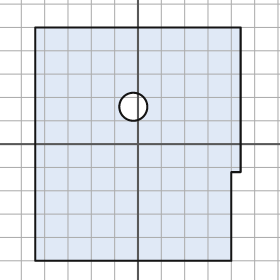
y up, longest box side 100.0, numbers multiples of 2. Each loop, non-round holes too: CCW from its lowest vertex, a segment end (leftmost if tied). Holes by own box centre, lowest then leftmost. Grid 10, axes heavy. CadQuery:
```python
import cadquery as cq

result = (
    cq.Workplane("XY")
    .moveTo(-44.0, -50.0)
    .lineTo(40.0, -50.0)
    .lineTo(40.0, -12.0)
    .lineTo(44.0, -12.0)
    .lineTo(44.0, 50.0)
    .lineTo(-44.0, 50.0)
    .close()
    .moveTo(-2.0, 16.0)
    .circle(6.0)
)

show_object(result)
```